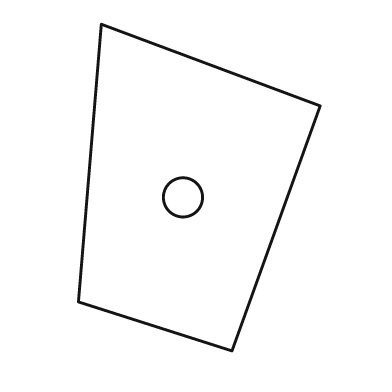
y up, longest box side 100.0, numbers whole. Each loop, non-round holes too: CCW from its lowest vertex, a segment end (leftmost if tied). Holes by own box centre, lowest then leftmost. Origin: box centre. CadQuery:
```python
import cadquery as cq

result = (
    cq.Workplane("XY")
    .moveTo(10.0, -50.0)
    .lineTo(37.0, 25.0)
    .lineTo(-30.0, 50.0)
    .lineTo(-37.0, -35.0)
    .close()
    .moveTo(-5.0, -3.0)
    .circle(6.0)
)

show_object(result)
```